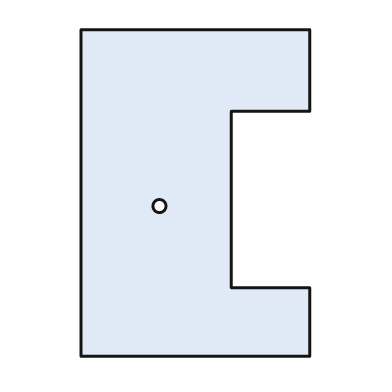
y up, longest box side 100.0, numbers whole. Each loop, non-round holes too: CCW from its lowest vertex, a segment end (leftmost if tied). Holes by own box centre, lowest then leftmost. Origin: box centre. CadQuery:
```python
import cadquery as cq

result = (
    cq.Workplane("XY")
    .moveTo(-35.0, -50.0)
    .lineTo(35.0, -50.0)
    .lineTo(35.0, -29.0)
    .lineTo(11.0, -29.0)
    .lineTo(11.0, 25.0)
    .lineTo(35.0, 25.0)
    .lineTo(35.0, 50.0)
    .lineTo(-35.0, 50.0)
    .close()
    .moveTo(-11.0, -4.0)
    .circle(2.0)
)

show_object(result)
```